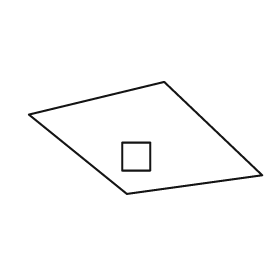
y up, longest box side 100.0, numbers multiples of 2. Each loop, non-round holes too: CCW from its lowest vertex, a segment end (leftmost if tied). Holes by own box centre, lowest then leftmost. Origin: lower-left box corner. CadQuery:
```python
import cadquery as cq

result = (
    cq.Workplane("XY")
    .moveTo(42.0, 0.0)
    .lineTo(100.0, 8.0)
    .lineTo(58.0, 48.0)
    .lineTo(0.0, 34.0)
    .close()
    .moveTo(40.0, 10.0)
    .lineTo(52.0, 10.0)
    .lineTo(52.0, 22.0)
    .lineTo(40.0, 22.0)
    .close()
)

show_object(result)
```